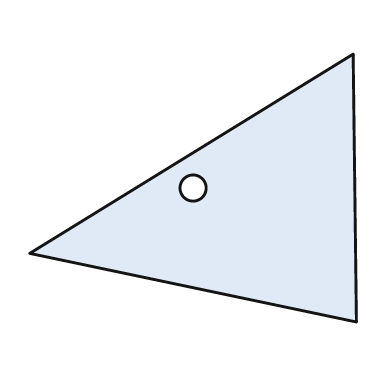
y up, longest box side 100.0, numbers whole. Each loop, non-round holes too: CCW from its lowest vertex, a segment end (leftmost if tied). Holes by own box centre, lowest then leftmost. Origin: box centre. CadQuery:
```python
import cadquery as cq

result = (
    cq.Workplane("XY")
    .moveTo(50.0, -41.0)
    .lineTo(49.0, 41.0)
    .lineTo(-50.0, -20.0)
    .close()
    .moveTo(0.0, 0.0)
    .circle(4.0)
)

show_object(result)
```